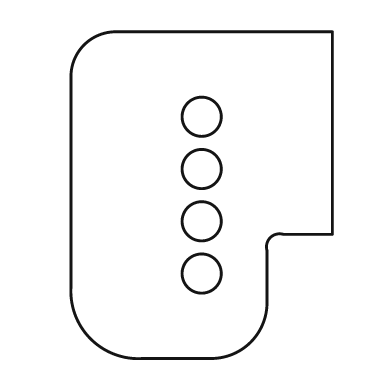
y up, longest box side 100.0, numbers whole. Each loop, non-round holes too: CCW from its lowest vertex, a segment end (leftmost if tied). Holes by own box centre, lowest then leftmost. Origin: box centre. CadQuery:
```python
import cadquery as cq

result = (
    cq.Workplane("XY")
    .moveTo(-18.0, -50.0)
    .lineTo(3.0, -50.0)
    .threePointArc((15.0, -45.0), (20.0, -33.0))
    .lineTo(20.0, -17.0)
    .threePointArc((21.0, -13.0), (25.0, -12.0))
    .lineTo(40.0, -12.0)
    .lineTo(40.0, 50.0)
    .lineTo(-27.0, 50.0)
    .threePointArc((-36.0, 46.0), (-40.0, 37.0))
    .lineTo(-40.0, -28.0)
    .threePointArc((-34.0, -44.0), (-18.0, -50.0))
    .close()
    .moveTo(0.0, -24.0)
    .circle(6.0)
    .moveTo(0.0, -8.0)
    .circle(6.0)
    .moveTo(0.0, 8.0)
    .circle(6.0)
    .moveTo(0.0, 24.0)
    .circle(6.0)
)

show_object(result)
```